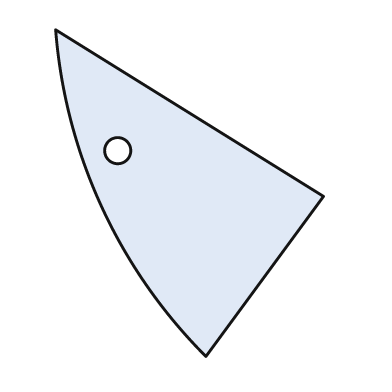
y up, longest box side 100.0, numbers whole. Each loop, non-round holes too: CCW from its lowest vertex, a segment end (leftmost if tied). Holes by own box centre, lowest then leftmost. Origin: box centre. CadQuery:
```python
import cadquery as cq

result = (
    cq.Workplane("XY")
    .moveTo(5.0, -50.0)
    .lineTo(41.0, -1.0)
    .lineTo(-41.0, 50.0)
    .threePointArc((-27.0, -4.0), (5.0, -50.0))
    .close()
    .moveTo(-22.0, 13.0)
    .circle(4.0)
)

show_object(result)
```